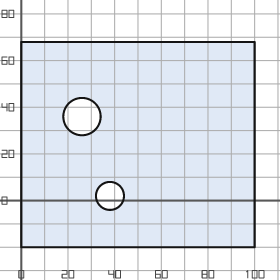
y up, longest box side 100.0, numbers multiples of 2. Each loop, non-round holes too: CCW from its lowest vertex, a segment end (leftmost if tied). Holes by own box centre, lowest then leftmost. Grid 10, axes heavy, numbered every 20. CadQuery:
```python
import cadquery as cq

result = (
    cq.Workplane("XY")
    .moveTo(0.0, -20.0)
    .lineTo(100.0, -20.0)
    .lineTo(100.0, 68.0)
    .lineTo(0.0, 68.0)
    .close()
    .moveTo(38.0, 2.0)
    .circle(6.0)
    .moveTo(26.0, 36.0)
    .circle(8.0)
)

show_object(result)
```